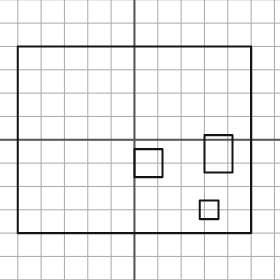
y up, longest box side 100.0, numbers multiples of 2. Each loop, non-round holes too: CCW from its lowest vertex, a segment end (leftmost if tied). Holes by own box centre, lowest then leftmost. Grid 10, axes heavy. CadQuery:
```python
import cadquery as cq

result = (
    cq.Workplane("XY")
    .moveTo(-50.0, -40.0)
    .lineTo(50.0, -40.0)
    .lineTo(50.0, 40.0)
    .lineTo(-50.0, 40.0)
    .close()
    .moveTo(28.0, -34.0)
    .lineTo(36.0, -34.0)
    .lineTo(36.0, -26.0)
    .lineTo(28.0, -26.0)
    .close()
    .moveTo(0.0, -16.0)
    .lineTo(12.0, -16.0)
    .lineTo(12.0, -4.0)
    .lineTo(0.0, -4.0)
    .close()
    .moveTo(30.0, -14.0)
    .lineTo(42.0, -14.0)
    .lineTo(42.0, 2.0)
    .lineTo(30.0, 2.0)
    .close()
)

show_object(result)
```